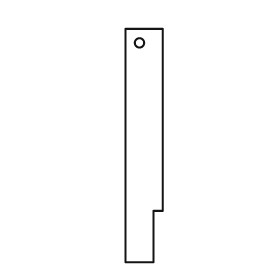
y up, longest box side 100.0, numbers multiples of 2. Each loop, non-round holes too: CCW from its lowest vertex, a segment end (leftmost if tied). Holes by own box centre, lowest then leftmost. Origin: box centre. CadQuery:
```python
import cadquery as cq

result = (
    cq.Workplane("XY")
    .moveTo(-8.0, -50.0)
    .lineTo(4.0, -50.0)
    .lineTo(4.0, -28.0)
    .lineTo(8.0, -28.0)
    .lineTo(8.0, 50.0)
    .lineTo(-8.0, 50.0)
    .close()
    .moveTo(-2.0, 44.0)
    .circle(2.0)
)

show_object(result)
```